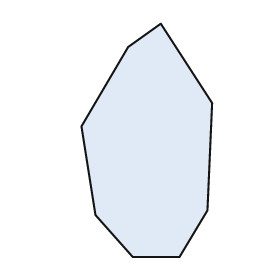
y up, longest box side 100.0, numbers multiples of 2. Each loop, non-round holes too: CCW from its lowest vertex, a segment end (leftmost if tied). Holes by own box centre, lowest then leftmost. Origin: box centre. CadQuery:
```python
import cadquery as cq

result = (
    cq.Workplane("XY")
    .moveTo(-6.0, -50.0)
    .lineTo(14.0, -50.0)
    .lineTo(26.0, -30.0)
    .lineTo(28.0, 16.0)
    .lineTo(6.0, 50.0)
    .lineTo(-8.0, 40.0)
    .lineTo(-28.0, 6.0)
    .lineTo(-22.0, -32.0)
    .close()
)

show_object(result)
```